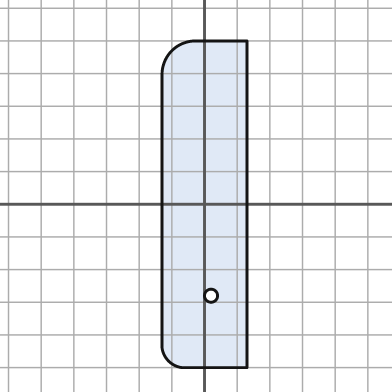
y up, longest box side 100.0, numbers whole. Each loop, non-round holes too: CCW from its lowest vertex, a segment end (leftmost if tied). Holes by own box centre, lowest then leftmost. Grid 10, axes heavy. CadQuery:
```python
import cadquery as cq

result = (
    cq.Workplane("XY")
    .moveTo(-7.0, -50.0)
    .lineTo(13.0, -50.0)
    .lineTo(13.0, 50.0)
    .lineTo(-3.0, 50.0)
    .threePointArc((-10.0, 47.0), (-13.0, 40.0))
    .lineTo(-13.0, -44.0)
    .threePointArc((-11.0, -48.0), (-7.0, -50.0))
    .close()
    .moveTo(2.0, -28.0)
    .circle(2.0)
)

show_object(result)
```